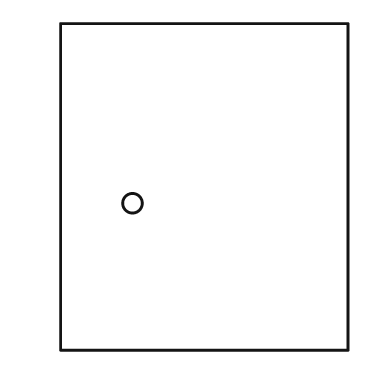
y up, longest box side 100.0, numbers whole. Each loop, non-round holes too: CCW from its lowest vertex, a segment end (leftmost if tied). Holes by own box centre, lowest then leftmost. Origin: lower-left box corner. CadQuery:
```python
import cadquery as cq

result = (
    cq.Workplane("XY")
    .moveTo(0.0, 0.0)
    .lineTo(88.0, 0.0)
    .lineTo(88.0, 100.0)
    .lineTo(0.0, 100.0)
    .close()
    .moveTo(22.0, 45.0)
    .circle(3.0)
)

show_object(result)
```